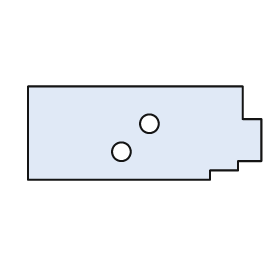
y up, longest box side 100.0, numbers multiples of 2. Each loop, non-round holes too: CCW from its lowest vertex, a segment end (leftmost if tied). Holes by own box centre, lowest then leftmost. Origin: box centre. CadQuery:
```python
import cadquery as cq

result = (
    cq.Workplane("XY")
    .moveTo(-50.0, -20.0)
    .lineTo(28.0, -20.0)
    .lineTo(28.0, -16.0)
    .lineTo(40.0, -16.0)
    .lineTo(40.0, -12.0)
    .lineTo(50.0, -12.0)
    .lineTo(50.0, 6.0)
    .lineTo(42.0, 6.0)
    .lineTo(42.0, 20.0)
    .lineTo(-50.0, 20.0)
    .close()
    .moveTo(-10.0, -8.0)
    .circle(4.0)
    .moveTo(2.0, 4.0)
    .circle(4.0)
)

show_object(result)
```